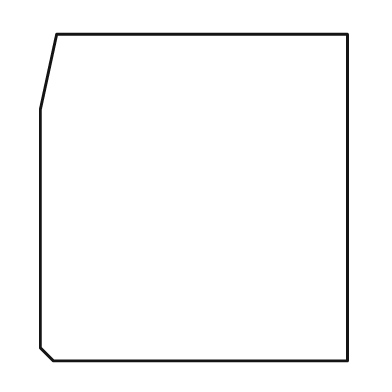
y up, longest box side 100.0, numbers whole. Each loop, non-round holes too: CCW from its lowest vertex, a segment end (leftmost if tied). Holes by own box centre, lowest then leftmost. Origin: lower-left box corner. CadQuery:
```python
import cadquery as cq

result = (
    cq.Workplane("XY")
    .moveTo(4.0, 0.0)
    .lineTo(94.0, 0.0)
    .lineTo(94.0, 100.0)
    .lineTo(5.0, 100.0)
    .lineTo(0.0, 77.0)
    .lineTo(0.0, 4.0)
    .close()
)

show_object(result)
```